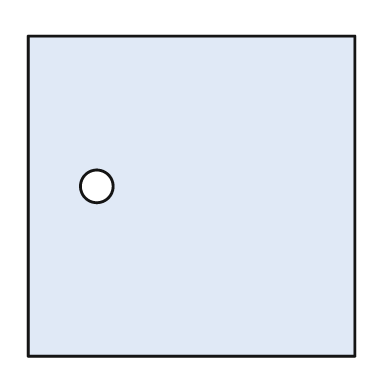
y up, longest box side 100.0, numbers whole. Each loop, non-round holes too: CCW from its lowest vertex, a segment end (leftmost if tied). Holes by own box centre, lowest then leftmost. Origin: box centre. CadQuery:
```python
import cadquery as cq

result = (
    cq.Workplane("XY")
    .moveTo(-50.0, -49.0)
    .lineTo(50.0, -49.0)
    .lineTo(50.0, 49.0)
    .lineTo(-50.0, 49.0)
    .close()
    .moveTo(-29.0, 3.0)
    .circle(5.0)
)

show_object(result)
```